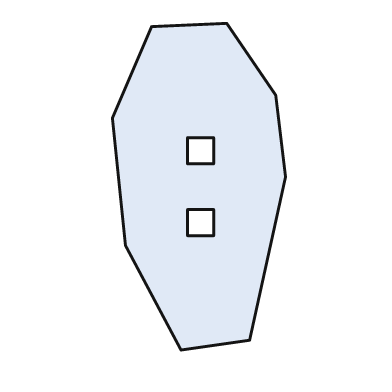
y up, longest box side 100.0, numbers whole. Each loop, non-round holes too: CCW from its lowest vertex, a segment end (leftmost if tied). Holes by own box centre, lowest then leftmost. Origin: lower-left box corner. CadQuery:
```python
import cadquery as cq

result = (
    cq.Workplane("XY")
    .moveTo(21.0, 0.0)
    .lineTo(42.0, 3.0)
    .lineTo(53.0, 53.0)
    .lineTo(50.0, 78.0)
    .lineTo(35.0, 100.0)
    .lineTo(12.0, 99.0)
    .lineTo(0.0, 71.0)
    .lineTo(4.0, 32.0)
    .close()
    .moveTo(23.0, 35.0)
    .lineTo(31.0, 35.0)
    .lineTo(31.0, 43.0)
    .lineTo(23.0, 43.0)
    .close()
    .moveTo(23.0, 57.0)
    .lineTo(31.0, 57.0)
    .lineTo(31.0, 65.0)
    .lineTo(23.0, 65.0)
    .close()
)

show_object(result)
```